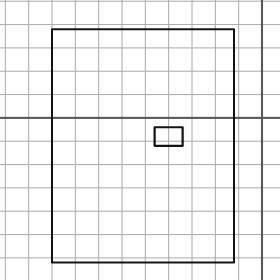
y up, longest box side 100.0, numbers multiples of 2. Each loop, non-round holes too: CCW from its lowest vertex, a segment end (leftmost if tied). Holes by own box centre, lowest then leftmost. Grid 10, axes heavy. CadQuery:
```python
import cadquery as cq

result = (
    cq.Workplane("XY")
    .moveTo(-90.0, -62.0)
    .lineTo(-12.0, -62.0)
    .lineTo(-12.0, 38.0)
    .lineTo(-90.0, 38.0)
    .close()
    .moveTo(-46.0, -12.0)
    .lineTo(-34.0, -12.0)
    .lineTo(-34.0, -4.0)
    .lineTo(-46.0, -4.0)
    .close()
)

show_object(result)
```